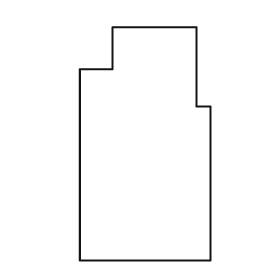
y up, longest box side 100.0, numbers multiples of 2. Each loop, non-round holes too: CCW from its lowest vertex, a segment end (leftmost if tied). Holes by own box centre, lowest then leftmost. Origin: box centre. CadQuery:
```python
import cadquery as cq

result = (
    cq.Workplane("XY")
    .moveTo(-28.0, -50.0)
    .lineTo(28.0, -50.0)
    .lineTo(28.0, 16.0)
    .lineTo(22.0, 16.0)
    .lineTo(22.0, 50.0)
    .lineTo(-14.0, 50.0)
    .lineTo(-14.0, 32.0)
    .lineTo(-28.0, 32.0)
    .close()
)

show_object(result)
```